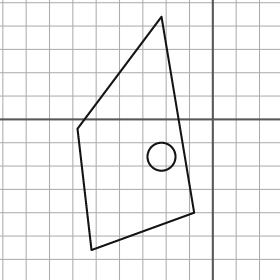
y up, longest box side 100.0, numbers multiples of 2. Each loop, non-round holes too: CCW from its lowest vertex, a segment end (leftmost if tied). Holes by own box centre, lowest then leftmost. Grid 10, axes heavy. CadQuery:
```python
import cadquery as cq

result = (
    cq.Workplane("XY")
    .moveTo(-52.0, -56.0)
    .lineTo(-8.0, -40.0)
    .lineTo(-22.0, 44.0)
    .lineTo(-58.0, -4.0)
    .close()
    .moveTo(-22.0, -16.0)
    .circle(6.0)
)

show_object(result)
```